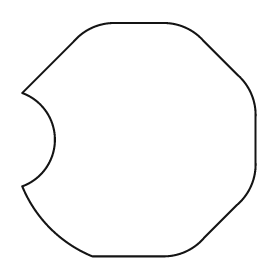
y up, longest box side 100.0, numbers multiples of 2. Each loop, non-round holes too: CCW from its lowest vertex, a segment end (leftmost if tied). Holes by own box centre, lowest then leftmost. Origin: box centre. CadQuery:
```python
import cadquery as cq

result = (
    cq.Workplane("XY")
    .moveTo(-20.0, -50.0)
    .lineTo(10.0, -50.0)
    .threePointArc((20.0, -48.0), (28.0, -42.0))
    .lineTo(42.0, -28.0)
    .threePointArc((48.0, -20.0), (50.0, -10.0))
    .lineTo(50.0, 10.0)
    .threePointArc((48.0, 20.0), (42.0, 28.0))
    .lineTo(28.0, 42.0)
    .threePointArc((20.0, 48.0), (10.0, 50.0))
    .lineTo(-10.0, 50.0)
    .threePointArc((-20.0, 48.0), (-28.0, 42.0))
    .lineTo(-50.0, 20.0)
    .threePointArc((-36.0, 0.0), (-50.0, -20.0))
    .threePointArc((-38.0, -38.0), (-20.0, -50.0))
    .close()
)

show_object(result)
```